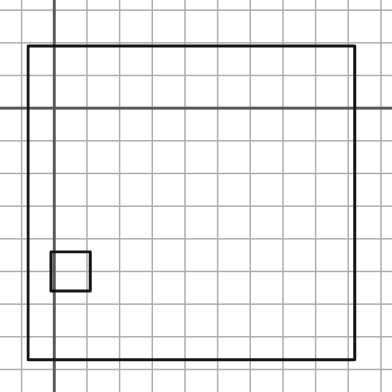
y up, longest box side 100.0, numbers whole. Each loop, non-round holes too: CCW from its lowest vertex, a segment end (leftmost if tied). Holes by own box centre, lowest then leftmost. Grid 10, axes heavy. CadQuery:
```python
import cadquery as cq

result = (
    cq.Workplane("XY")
    .moveTo(-8.0, -77.0)
    .lineTo(92.0, -77.0)
    .lineTo(92.0, 19.0)
    .lineTo(-8.0, 19.0)
    .close()
    .moveTo(-1.0, -56.0)
    .lineTo(11.0, -56.0)
    .lineTo(11.0, -44.0)
    .lineTo(-1.0, -44.0)
    .close()
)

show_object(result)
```